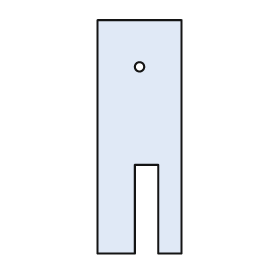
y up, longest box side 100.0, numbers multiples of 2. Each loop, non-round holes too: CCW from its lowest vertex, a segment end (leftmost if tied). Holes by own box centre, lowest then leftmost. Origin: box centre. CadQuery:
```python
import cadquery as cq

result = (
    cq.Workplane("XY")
    .moveTo(-18.0, -50.0)
    .lineTo(-2.0, -50.0)
    .lineTo(-2.0, -12.0)
    .lineTo(8.0, -12.0)
    .lineTo(8.0, -50.0)
    .lineTo(18.0, -50.0)
    .lineTo(18.0, 50.0)
    .lineTo(-18.0, 50.0)
    .close()
    .moveTo(0.0, 30.0)
    .circle(2.0)
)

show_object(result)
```